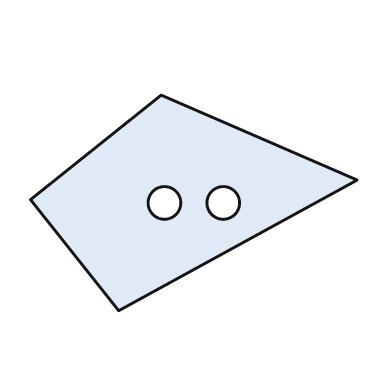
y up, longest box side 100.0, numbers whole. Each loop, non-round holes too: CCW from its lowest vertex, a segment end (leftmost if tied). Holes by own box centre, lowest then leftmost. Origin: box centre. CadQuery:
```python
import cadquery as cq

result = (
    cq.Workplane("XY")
    .moveTo(-23.0, -33.0)
    .lineTo(50.0, 7.0)
    .lineTo(-10.0, 33.0)
    .lineTo(-50.0, 1.0)
    .close()
    .moveTo(-9.0, 0.0)
    .circle(5.0)
    .moveTo(9.0, 0.0)
    .circle(5.0)
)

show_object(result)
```